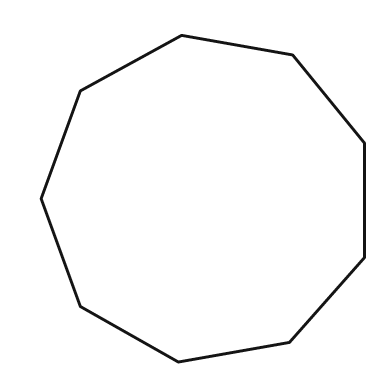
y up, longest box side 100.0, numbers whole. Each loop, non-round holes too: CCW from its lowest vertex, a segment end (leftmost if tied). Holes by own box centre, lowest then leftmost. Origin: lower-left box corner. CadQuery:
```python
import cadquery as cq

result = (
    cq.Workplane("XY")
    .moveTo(42.0, 0.0)
    .lineTo(76.0, 6.0)
    .lineTo(99.0, 32.0)
    .lineTo(99.0, 67.0)
    .lineTo(77.0, 94.0)
    .lineTo(43.0, 100.0)
    .lineTo(12.0, 83.0)
    .lineTo(0.0, 50.0)
    .lineTo(12.0, 17.0)
    .close()
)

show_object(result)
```